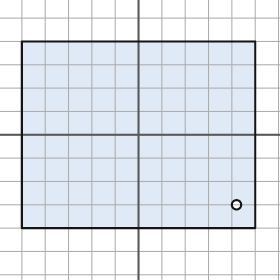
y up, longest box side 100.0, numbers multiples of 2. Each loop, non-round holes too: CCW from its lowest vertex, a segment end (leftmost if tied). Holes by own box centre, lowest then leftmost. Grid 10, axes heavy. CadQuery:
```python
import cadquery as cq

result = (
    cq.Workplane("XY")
    .moveTo(-50.0, -40.0)
    .lineTo(50.0, -40.0)
    .lineTo(50.0, 40.0)
    .lineTo(-50.0, 40.0)
    .close()
    .moveTo(42.0, -30.0)
    .circle(2.0)
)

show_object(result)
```